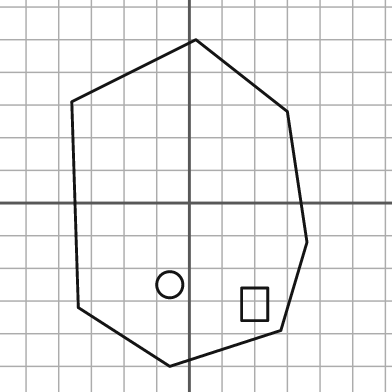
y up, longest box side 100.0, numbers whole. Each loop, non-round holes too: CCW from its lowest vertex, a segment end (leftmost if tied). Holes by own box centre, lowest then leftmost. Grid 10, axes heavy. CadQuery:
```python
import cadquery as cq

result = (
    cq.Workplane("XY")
    .moveTo(-6.0, -50.0)
    .lineTo(28.0, -39.0)
    .lineTo(36.0, -12.0)
    .lineTo(30.0, 28.0)
    .lineTo(2.0, 50.0)
    .lineTo(-36.0, 31.0)
    .lineTo(-34.0, -32.0)
    .close()
    .moveTo(16.0, -36.0)
    .lineTo(24.0, -36.0)
    .lineTo(24.0, -26.0)
    .lineTo(16.0, -26.0)
    .close()
    .moveTo(-6.0, -25.0)
    .circle(4.0)
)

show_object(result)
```